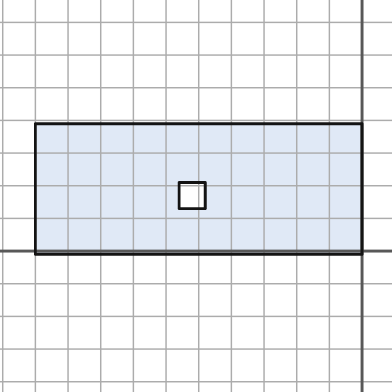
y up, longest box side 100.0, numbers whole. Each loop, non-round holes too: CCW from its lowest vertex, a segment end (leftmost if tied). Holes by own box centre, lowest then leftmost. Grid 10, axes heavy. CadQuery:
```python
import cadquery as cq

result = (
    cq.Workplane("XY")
    .moveTo(-100.0, -1.0)
    .lineTo(0.0, -1.0)
    .lineTo(0.0, 39.0)
    .lineTo(-100.0, 39.0)
    .close()
    .moveTo(-56.0, 13.0)
    .lineTo(-48.0, 13.0)
    .lineTo(-48.0, 21.0)
    .lineTo(-56.0, 21.0)
    .close()
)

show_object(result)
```